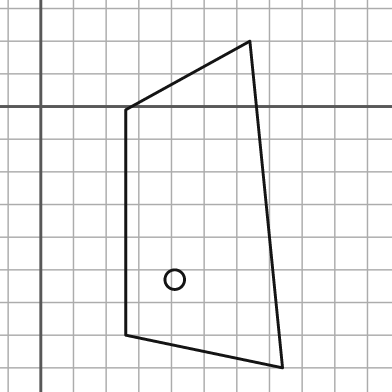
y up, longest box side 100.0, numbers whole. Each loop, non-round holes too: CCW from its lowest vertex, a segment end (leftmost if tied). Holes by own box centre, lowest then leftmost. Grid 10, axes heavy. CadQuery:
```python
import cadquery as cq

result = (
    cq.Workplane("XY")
    .moveTo(74.0, -80.0)
    .lineTo(64.0, 20.0)
    .lineTo(26.0, -1.0)
    .lineTo(26.0, -70.0)
    .close()
    .moveTo(41.0, -53.0)
    .circle(3.0)
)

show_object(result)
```